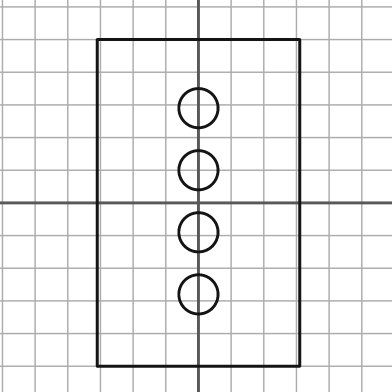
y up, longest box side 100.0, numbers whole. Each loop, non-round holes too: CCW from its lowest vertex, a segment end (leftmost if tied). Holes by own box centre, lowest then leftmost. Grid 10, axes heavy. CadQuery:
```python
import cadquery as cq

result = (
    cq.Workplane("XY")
    .moveTo(-31.0, -50.0)
    .lineTo(31.0, -50.0)
    .lineTo(31.0, 50.0)
    .lineTo(-31.0, 50.0)
    .close()
    .moveTo(0.0, -28.0)
    .circle(6.0)
    .moveTo(0.0, -9.0)
    .circle(6.0)
    .moveTo(0.0, 10.0)
    .circle(6.0)
    .moveTo(0.0, 29.0)
    .circle(6.0)
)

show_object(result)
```